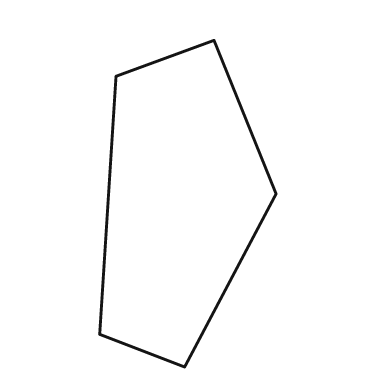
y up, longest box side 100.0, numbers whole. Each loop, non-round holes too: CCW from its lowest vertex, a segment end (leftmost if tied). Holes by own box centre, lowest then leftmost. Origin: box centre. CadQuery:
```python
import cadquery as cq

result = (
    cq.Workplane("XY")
    .moveTo(-1.0, -50.0)
    .lineTo(27.0, 3.0)
    .lineTo(8.0, 50.0)
    .lineTo(-22.0, 39.0)
    .lineTo(-27.0, -40.0)
    .close()
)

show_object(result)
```